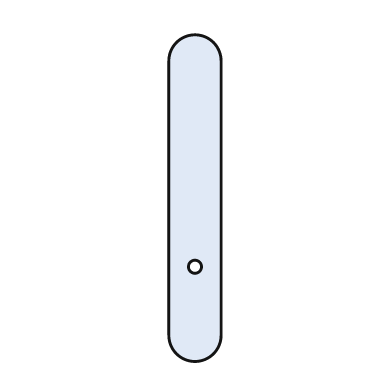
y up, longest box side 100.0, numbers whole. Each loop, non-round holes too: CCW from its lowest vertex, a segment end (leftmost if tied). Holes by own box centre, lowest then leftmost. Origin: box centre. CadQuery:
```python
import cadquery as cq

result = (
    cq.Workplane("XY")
    .moveTo(-8.0, -42.0)
    .threePointArc((0.0, -50.0), (8.0, -42.0))
    .lineTo(8.0, 42.0)
    .threePointArc((0.0, 50.0), (-8.0, 42.0))
    .close()
    .moveTo(0.0, -21.0)
    .circle(2.0)
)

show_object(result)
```